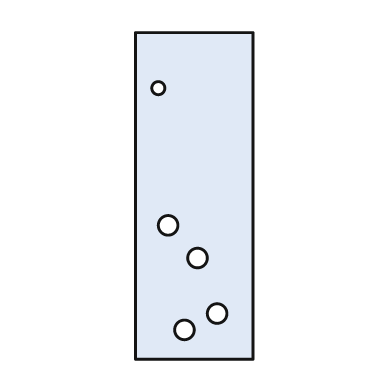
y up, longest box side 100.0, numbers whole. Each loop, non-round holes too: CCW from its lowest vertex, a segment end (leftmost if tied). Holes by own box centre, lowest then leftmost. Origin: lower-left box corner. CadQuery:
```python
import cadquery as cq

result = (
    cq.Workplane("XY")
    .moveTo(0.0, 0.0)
    .lineTo(36.0, 0.0)
    .lineTo(36.0, 100.0)
    .lineTo(0.0, 100.0)
    .close()
    .moveTo(15.0, 9.0)
    .circle(3.0)
    .moveTo(25.0, 14.0)
    .circle(3.0)
    .moveTo(19.0, 31.0)
    .circle(3.0)
    .moveTo(10.0, 41.0)
    .circle(3.0)
    .moveTo(7.0, 83.0)
    .circle(2.0)
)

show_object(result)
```